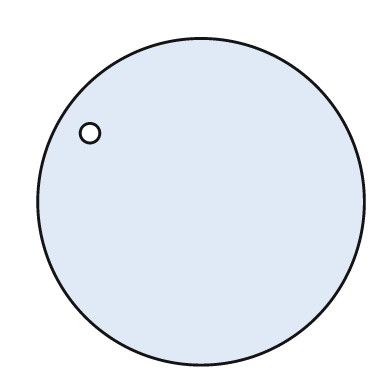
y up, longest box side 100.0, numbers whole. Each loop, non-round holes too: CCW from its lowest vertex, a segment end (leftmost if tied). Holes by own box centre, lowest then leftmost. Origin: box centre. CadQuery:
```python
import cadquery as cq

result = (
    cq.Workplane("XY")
    .moveTo(0.0, 0.0)
    .circle(50.0)
    .moveTo(-34.0, 21.0)
    .circle(3.0)
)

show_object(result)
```